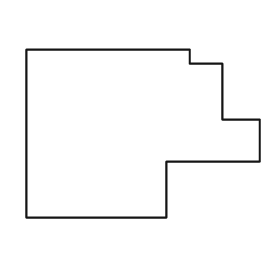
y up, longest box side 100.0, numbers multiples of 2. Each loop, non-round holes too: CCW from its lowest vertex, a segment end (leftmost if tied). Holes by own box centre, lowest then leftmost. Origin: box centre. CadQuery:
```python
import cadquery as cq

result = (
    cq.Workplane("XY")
    .moveTo(-50.0, -36.0)
    .lineTo(10.0, -36.0)
    .lineTo(10.0, -12.0)
    .lineTo(50.0, -12.0)
    .lineTo(50.0, 6.0)
    .lineTo(34.0, 6.0)
    .lineTo(34.0, 30.0)
    .lineTo(20.0, 30.0)
    .lineTo(20.0, 36.0)
    .lineTo(-50.0, 36.0)
    .close()
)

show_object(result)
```